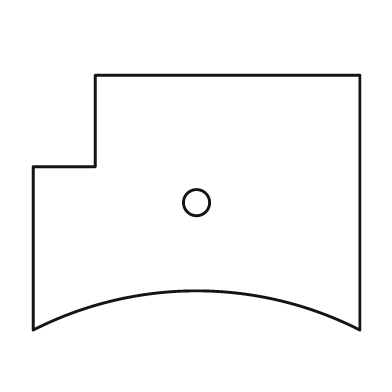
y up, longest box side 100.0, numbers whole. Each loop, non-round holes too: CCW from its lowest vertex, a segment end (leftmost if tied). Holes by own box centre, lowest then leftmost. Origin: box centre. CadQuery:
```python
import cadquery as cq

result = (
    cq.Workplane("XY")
    .moveTo(-50.0, -39.0)
    .threePointArc((0.0, -27.0), (50.0, -39.0))
    .lineTo(50.0, 39.0)
    .lineTo(-31.0, 39.0)
    .lineTo(-31.0, 11.0)
    .lineTo(-50.0, 11.0)
    .close()
    .moveTo(0.0, 0.0)
    .circle(4.0)
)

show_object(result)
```